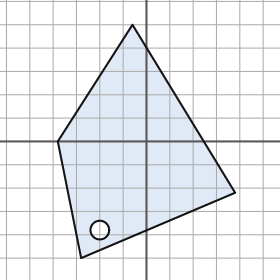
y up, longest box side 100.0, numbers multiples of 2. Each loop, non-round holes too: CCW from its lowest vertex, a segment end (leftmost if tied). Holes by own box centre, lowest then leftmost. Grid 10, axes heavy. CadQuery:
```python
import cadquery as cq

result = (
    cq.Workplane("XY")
    .moveTo(-28.0, -50.0)
    .lineTo(38.0, -22.0)
    .lineTo(-6.0, 50.0)
    .lineTo(-38.0, 0.0)
    .close()
    .moveTo(-20.0, -38.0)
    .circle(4.0)
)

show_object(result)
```